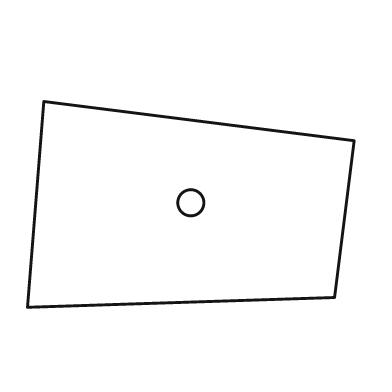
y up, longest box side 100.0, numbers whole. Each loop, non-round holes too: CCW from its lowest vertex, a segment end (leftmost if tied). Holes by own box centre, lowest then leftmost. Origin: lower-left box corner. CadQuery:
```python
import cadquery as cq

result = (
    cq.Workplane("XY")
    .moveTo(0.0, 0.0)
    .lineTo(94.0, 3.0)
    .lineTo(100.0, 51.0)
    .lineTo(5.0, 63.0)
    .close()
    .moveTo(50.0, 32.0)
    .circle(4.0)
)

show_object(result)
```